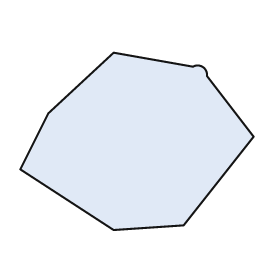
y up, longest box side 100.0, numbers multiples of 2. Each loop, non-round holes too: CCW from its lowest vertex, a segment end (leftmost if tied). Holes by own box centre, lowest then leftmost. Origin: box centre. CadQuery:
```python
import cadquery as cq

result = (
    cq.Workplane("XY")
    .moveTo(-10.0, -38.0)
    .lineTo(20.0, -36.0)
    .lineTo(50.0, 2.0)
    .lineTo(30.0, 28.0)
    .threePointArc((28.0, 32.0), (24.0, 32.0))
    .lineTo(-10.0, 38.0)
    .lineTo(-38.0, 12.0)
    .lineTo(-50.0, -12.0)
    .close()
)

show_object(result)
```